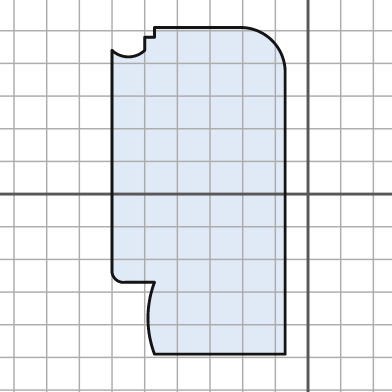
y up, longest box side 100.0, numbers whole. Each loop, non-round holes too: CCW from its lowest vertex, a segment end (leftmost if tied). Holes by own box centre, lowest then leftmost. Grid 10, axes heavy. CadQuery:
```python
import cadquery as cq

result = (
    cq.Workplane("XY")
    .moveTo(-47.0, -49.0)
    .lineTo(-7.0, -49.0)
    .lineTo(-7.0, 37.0)
    .threePointArc((-11.0, 47.0), (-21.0, 51.0))
    .lineTo(-47.0, 51.0)
    .lineTo(-47.0, 48.0)
    .lineTo(-50.0, 48.0)
    .lineTo(-50.0, 44.0)
    .threePointArc((-55.0, 42.0), (-60.0, 44.0))
    .lineTo(-60.0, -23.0)
    .threePointArc((-59.0, -26.0), (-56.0, -27.0))
    .lineTo(-47.0, -27.0)
    .threePointArc((-49.0, -38.0), (-47.0, -49.0))
    .close()
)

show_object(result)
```